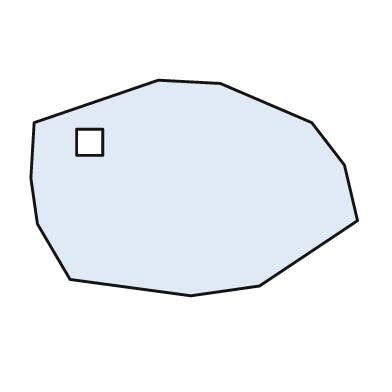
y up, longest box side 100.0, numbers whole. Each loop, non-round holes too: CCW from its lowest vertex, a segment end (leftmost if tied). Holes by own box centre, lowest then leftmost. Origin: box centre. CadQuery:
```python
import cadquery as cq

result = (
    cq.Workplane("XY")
    .moveTo(-1.0, -33.0)
    .lineTo(20.0, -30.0)
    .lineTo(50.0, -10.0)
    .lineTo(46.0, 7.0)
    .lineTo(36.0, 20.0)
    .lineTo(8.0, 32.0)
    .lineTo(-11.0, 33.0)
    .lineTo(-49.0, 20.0)
    .lineTo(-50.0, 3.0)
    .lineTo(-48.0, -11.0)
    .lineTo(-38.0, -28.0)
    .close()
    .moveTo(-36.0, 10.0)
    .lineTo(-28.0, 10.0)
    .lineTo(-28.0, 18.0)
    .lineTo(-36.0, 18.0)
    .close()
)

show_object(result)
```